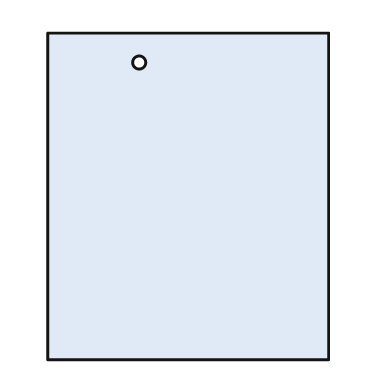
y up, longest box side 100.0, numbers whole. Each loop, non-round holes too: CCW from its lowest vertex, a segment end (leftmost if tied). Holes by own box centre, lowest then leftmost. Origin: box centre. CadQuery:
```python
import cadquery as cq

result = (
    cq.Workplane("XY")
    .moveTo(-43.0, -50.0)
    .lineTo(43.0, -50.0)
    .lineTo(43.0, 50.0)
    .lineTo(-43.0, 50.0)
    .close()
    .moveTo(-15.0, 41.0)
    .circle(2.0)
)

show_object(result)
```